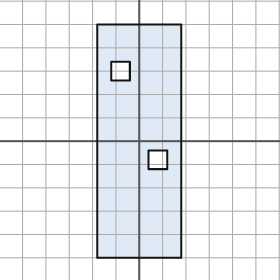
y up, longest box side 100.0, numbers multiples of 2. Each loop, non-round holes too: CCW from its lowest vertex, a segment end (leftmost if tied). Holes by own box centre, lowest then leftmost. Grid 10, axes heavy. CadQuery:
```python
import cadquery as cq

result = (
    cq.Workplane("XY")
    .moveTo(-18.0, -50.0)
    .lineTo(18.0, -50.0)
    .lineTo(18.0, 50.0)
    .lineTo(-18.0, 50.0)
    .close()
    .moveTo(4.0, -12.0)
    .lineTo(12.0, -12.0)
    .lineTo(12.0, -4.0)
    .lineTo(4.0, -4.0)
    .close()
    .moveTo(-12.0, 26.0)
    .lineTo(-4.0, 26.0)
    .lineTo(-4.0, 34.0)
    .lineTo(-12.0, 34.0)
    .close()
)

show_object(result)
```